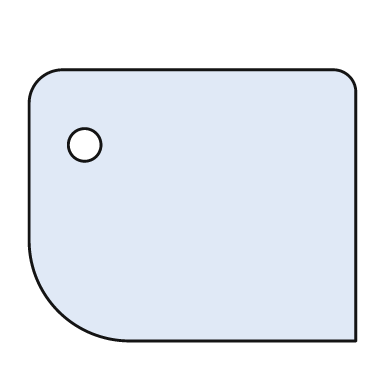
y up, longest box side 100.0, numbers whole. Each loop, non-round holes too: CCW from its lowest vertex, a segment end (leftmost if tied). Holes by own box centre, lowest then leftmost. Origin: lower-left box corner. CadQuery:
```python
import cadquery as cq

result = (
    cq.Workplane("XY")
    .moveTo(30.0, 0.0)
    .lineTo(100.0, 0.0)
    .lineTo(100.0, 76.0)
    .threePointArc((98.0, 81.0), (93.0, 83.0))
    .lineTo(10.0, 83.0)
    .threePointArc((3.0, 80.0), (0.0, 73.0))
    .lineTo(0.0, 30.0)
    .threePointArc((9.0, 9.0), (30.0, 0.0))
    .close()
    .moveTo(17.0, 60.0)
    .circle(5.0)
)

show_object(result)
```